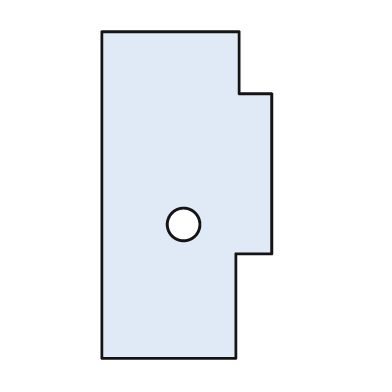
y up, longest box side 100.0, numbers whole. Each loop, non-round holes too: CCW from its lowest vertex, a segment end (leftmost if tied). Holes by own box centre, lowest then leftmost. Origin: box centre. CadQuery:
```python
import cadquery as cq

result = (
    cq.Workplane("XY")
    .moveTo(-26.0, -50.0)
    .lineTo(15.0, -50.0)
    .lineTo(15.0, -18.0)
    .lineTo(26.0, -18.0)
    .lineTo(26.0, 31.0)
    .lineTo(16.0, 31.0)
    .lineTo(16.0, 50.0)
    .lineTo(-26.0, 50.0)
    .close()
    .moveTo(-1.0, -9.0)
    .circle(5.0)
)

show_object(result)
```